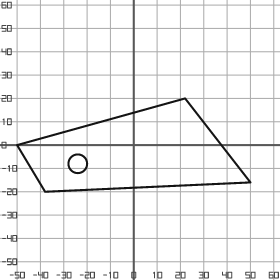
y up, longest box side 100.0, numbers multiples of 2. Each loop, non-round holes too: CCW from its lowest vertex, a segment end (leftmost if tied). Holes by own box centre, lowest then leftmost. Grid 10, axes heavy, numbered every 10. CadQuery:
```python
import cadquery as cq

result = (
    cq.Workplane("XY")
    .moveTo(-38.0, -20.0)
    .lineTo(50.0, -16.0)
    .lineTo(22.0, 20.0)
    .lineTo(-50.0, 0.0)
    .close()
    .moveTo(-24.0, -8.0)
    .circle(4.0)
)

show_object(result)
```